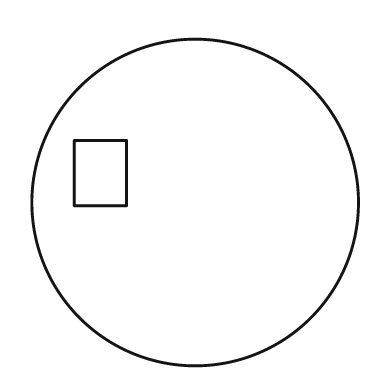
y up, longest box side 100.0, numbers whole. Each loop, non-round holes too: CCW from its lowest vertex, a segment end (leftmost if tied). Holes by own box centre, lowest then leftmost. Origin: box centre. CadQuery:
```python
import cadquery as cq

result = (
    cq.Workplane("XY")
    .moveTo(0.0, 0.0)
    .circle(50.0)
    .moveTo(-37.0, -1.0)
    .lineTo(-21.0, -1.0)
    .lineTo(-21.0, 19.0)
    .lineTo(-37.0, 19.0)
    .close()
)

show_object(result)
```